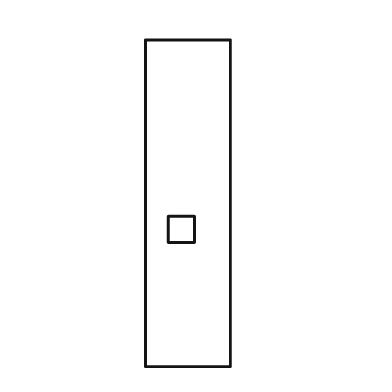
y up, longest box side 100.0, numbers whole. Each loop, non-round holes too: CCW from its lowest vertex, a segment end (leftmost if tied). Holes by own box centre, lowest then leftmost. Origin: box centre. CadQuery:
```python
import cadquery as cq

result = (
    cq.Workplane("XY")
    .moveTo(-13.0, -50.0)
    .lineTo(13.0, -50.0)
    .lineTo(13.0, 50.0)
    .lineTo(-13.0, 50.0)
    .close()
    .moveTo(-6.0, -12.0)
    .lineTo(2.0, -12.0)
    .lineTo(2.0, -4.0)
    .lineTo(-6.0, -4.0)
    .close()
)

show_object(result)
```